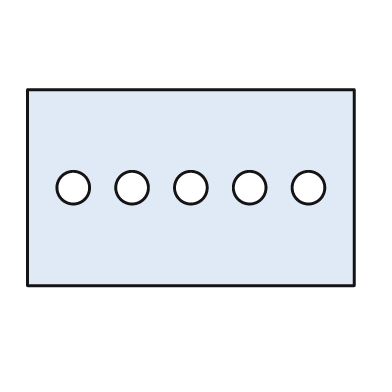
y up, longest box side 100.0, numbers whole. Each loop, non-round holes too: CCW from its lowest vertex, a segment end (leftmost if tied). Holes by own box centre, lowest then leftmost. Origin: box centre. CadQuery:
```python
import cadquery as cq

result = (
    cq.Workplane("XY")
    .moveTo(-50.0, -30.0)
    .lineTo(50.0, -30.0)
    .lineTo(50.0, 30.0)
    .lineTo(-50.0, 30.0)
    .close()
    .moveTo(-36.0, 0.0)
    .circle(5.0)
    .moveTo(-18.0, 0.0)
    .circle(5.0)
    .moveTo(0.0, 0.0)
    .circle(5.0)
    .moveTo(18.0, 0.0)
    .circle(5.0)
    .moveTo(36.0, 0.0)
    .circle(5.0)
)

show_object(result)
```